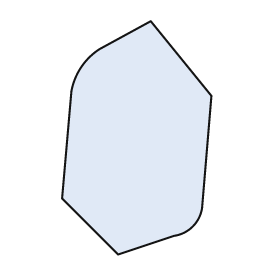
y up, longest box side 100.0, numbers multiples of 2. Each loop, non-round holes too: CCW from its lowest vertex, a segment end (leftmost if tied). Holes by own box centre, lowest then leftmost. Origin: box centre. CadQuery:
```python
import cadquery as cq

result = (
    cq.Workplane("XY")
    .moveTo(-8.0, -50.0)
    .lineTo(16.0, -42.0)
    .threePointArc((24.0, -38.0), (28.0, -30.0))
    .lineTo(32.0, 18.0)
    .lineTo(6.0, 50.0)
    .lineTo(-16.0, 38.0)
    .threePointArc((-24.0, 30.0), (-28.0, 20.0))
    .lineTo(-32.0, -26.0)
    .close()
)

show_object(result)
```